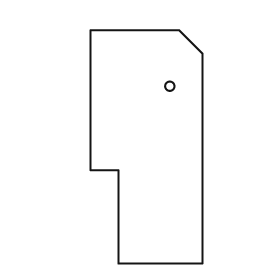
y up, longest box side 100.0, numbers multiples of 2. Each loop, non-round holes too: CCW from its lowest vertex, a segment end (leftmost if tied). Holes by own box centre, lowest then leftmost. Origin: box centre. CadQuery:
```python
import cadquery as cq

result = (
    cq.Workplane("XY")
    .moveTo(-12.0, -50.0)
    .lineTo(24.0, -50.0)
    .lineTo(24.0, 40.0)
    .lineTo(14.0, 50.0)
    .lineTo(-24.0, 50.0)
    .lineTo(-24.0, -10.0)
    .lineTo(-12.0, -10.0)
    .close()
    .moveTo(10.0, 26.0)
    .circle(2.0)
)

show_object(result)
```